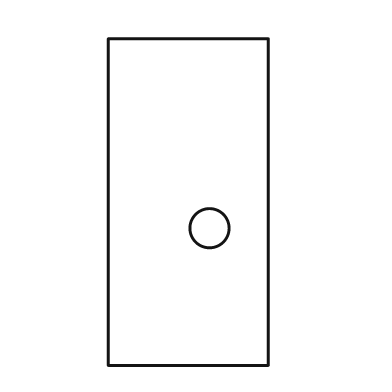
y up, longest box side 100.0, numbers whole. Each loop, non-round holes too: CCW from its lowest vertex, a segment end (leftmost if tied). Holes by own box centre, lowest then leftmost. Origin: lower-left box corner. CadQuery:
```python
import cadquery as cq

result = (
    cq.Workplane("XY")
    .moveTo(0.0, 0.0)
    .lineTo(49.0, 0.0)
    .lineTo(49.0, 100.0)
    .lineTo(0.0, 100.0)
    .close()
    .moveTo(31.0, 42.0)
    .circle(6.0)
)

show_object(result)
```